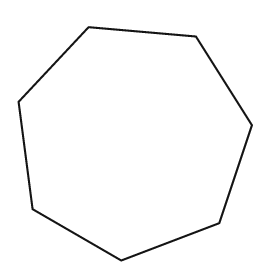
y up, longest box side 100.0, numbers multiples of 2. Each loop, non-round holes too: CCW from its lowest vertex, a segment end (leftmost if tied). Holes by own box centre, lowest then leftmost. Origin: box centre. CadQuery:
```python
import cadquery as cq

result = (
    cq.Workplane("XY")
    .moveTo(-6.0, -50.0)
    .lineTo(36.0, -34.0)
    .lineTo(50.0, 8.0)
    .lineTo(26.0, 46.0)
    .lineTo(-20.0, 50.0)
    .lineTo(-50.0, 18.0)
    .lineTo(-44.0, -28.0)
    .close()
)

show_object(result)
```